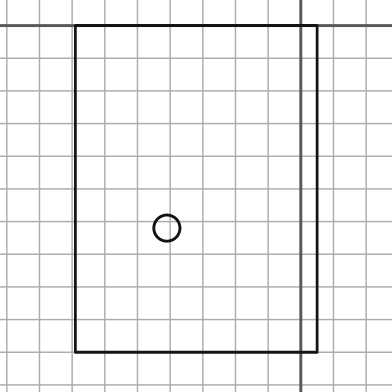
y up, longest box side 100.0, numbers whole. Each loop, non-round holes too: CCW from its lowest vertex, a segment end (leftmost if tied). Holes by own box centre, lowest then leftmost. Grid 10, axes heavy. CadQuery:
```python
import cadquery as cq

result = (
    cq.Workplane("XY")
    .moveTo(-69.0, -100.0)
    .lineTo(5.0, -100.0)
    .lineTo(5.0, 0.0)
    .lineTo(-69.0, 0.0)
    .close()
    .moveTo(-41.0, -62.0)
    .circle(4.0)
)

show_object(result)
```